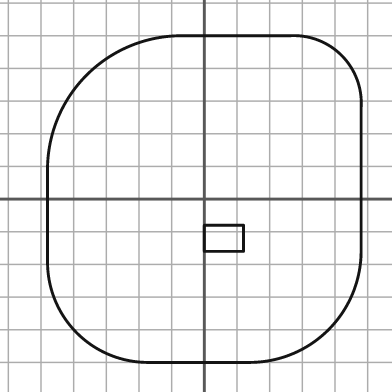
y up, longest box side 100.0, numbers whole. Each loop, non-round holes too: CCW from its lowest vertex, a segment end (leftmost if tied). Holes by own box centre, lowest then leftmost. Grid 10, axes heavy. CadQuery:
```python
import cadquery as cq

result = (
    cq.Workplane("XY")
    .moveTo(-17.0, -50.0)
    .lineTo(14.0, -50.0)
    .threePointArc((38.0, -40.0), (48.0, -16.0))
    .lineTo(48.0, 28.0)
    .threePointArc((42.0, 44.0), (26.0, 50.0))
    .lineTo(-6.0, 50.0)
    .threePointArc((-36.0, 38.0), (-48.0, 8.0))
    .lineTo(-48.0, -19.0)
    .threePointArc((-39.0, -41.0), (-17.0, -50.0))
    .close()
    .moveTo(0.0, -16.0)
    .lineTo(12.0, -16.0)
    .lineTo(12.0, -8.0)
    .lineTo(0.0, -8.0)
    .close()
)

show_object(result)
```